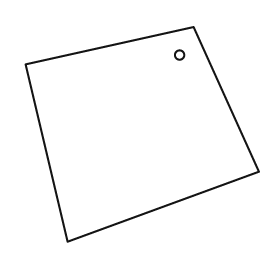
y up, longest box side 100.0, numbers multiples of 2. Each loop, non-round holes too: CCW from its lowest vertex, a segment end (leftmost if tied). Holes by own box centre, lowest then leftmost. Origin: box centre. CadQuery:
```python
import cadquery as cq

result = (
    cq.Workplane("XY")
    .moveTo(-32.0, -46.0)
    .lineTo(50.0, -16.0)
    .lineTo(22.0, 46.0)
    .lineTo(-50.0, 30.0)
    .close()
    .moveTo(16.0, 34.0)
    .circle(2.0)
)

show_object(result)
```